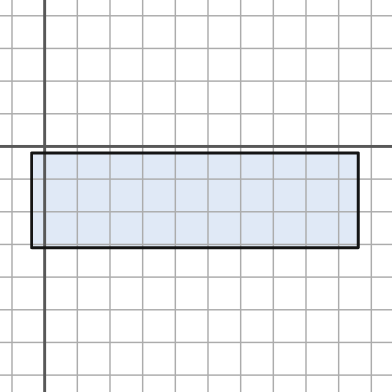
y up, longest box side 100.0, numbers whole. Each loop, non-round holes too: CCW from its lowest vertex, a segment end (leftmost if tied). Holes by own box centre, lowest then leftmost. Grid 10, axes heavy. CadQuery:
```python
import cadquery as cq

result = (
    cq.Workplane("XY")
    .moveTo(-4.0, -31.0)
    .lineTo(96.0, -31.0)
    .lineTo(96.0, -2.0)
    .lineTo(-4.0, -2.0)
    .close()
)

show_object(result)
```